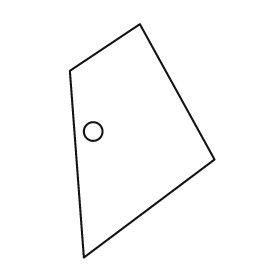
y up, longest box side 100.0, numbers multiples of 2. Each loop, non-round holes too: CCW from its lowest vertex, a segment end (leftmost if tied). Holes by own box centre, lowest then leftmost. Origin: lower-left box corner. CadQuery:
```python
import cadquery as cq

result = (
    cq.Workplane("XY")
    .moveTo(6.0, 0.0)
    .lineTo(62.0, 42.0)
    .lineTo(30.0, 100.0)
    .lineTo(0.0, 80.0)
    .close()
    .moveTo(10.0, 54.0)
    .circle(4.0)
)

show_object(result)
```